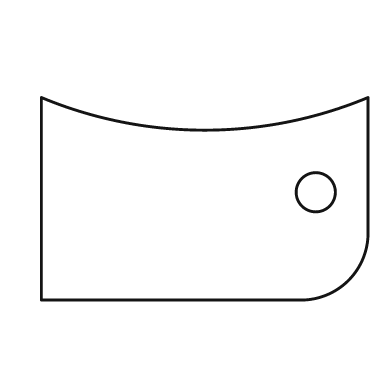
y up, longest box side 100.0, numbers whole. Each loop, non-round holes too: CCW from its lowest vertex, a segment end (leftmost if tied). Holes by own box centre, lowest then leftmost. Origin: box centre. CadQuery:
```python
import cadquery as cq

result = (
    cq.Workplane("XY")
    .moveTo(-50.0, -31.0)
    .lineTo(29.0, -31.0)
    .threePointArc((44.0, -25.0), (50.0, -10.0))
    .lineTo(50.0, 31.0)
    .threePointArc((0.0, 21.0), (-50.0, 31.0))
    .close()
    .moveTo(34.0, 2.0)
    .circle(6.0)
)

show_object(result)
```